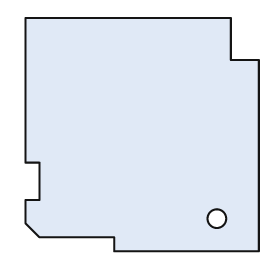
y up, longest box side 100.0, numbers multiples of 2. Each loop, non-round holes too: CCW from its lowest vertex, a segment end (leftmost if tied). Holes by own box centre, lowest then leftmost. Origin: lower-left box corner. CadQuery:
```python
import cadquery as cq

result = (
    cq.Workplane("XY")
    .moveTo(38.0, 0.0)
    .lineTo(100.0, 0.0)
    .lineTo(100.0, 82.0)
    .lineTo(88.0, 82.0)
    .lineTo(88.0, 100.0)
    .lineTo(0.0, 100.0)
    .lineTo(0.0, 38.0)
    .lineTo(6.0, 38.0)
    .lineTo(6.0, 22.0)
    .lineTo(0.0, 22.0)
    .lineTo(0.0, 12.0)
    .lineTo(6.0, 6.0)
    .lineTo(38.0, 6.0)
    .close()
    .moveTo(82.0, 14.0)
    .circle(4.0)
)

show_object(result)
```